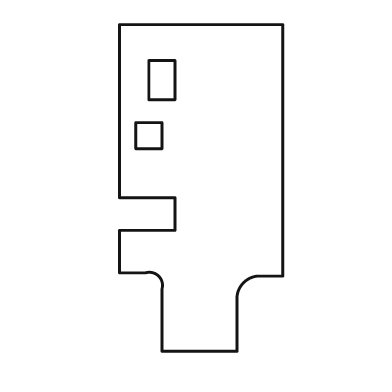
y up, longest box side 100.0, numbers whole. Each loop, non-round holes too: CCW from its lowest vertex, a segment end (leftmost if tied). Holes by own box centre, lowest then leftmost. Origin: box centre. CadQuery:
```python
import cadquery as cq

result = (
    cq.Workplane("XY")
    .moveTo(-12.0, -50.0)
    .lineTo(11.0, -50.0)
    .lineTo(11.0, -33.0)
    .threePointArc((13.0, -29.0), (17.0, -27.0))
    .lineTo(25.0, -27.0)
    .lineTo(25.0, 50.0)
    .lineTo(-25.0, 50.0)
    .lineTo(-25.0, -3.0)
    .lineTo(-8.0, -3.0)
    .lineTo(-8.0, -13.0)
    .lineTo(-25.0, -13.0)
    .lineTo(-25.0, -26.0)
    .lineTo(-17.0, -26.0)
    .threePointArc((-13.0, -27.0), (-12.0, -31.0))
    .close()
    .moveTo(-20.0, 12.0)
    .lineTo(-12.0, 12.0)
    .lineTo(-12.0, 20.0)
    .lineTo(-20.0, 20.0)
    .close()
    .moveTo(-16.0, 27.0)
    .lineTo(-8.0, 27.0)
    .lineTo(-8.0, 39.0)
    .lineTo(-16.0, 39.0)
    .close()
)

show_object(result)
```